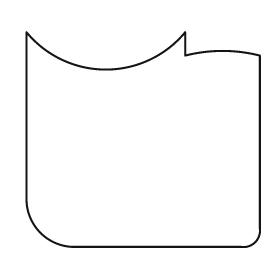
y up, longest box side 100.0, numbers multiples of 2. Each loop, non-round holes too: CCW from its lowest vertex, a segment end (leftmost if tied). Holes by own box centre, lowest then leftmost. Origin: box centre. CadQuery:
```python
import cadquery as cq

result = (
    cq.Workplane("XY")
    .moveTo(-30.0, -46.0)
    .lineTo(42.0, -46.0)
    .threePointArc((48.0, -44.0), (50.0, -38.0))
    .lineTo(50.0, 36.0)
    .threePointArc((34.0, 38.0), (18.0, 36.0))
    .lineTo(18.0, 46.0)
    .threePointArc((-16.0, 30.0), (-50.0, 46.0))
    .lineTo(-50.0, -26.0)
    .threePointArc((-44.0, -40.0), (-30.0, -46.0))
    .close()
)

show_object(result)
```